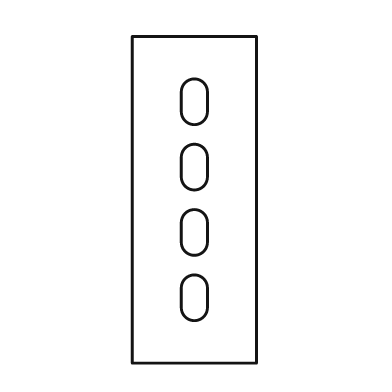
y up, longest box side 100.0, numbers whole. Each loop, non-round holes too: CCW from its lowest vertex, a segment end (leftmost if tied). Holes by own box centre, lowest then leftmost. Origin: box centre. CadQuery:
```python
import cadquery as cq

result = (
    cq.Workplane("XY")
    .moveTo(-19.0, -50.0)
    .lineTo(19.0, -50.0)
    .lineTo(19.0, 50.0)
    .lineTo(-19.0, 50.0)
    .close()
    .moveTo(-4.0, -33.0)
    .threePointArc((0.0, -37.0), (4.0, -33.0))
    .lineTo(4.0, -27.0)
    .threePointArc((0.0, -23.0), (-4.0, -27.0))
    .close()
    .moveTo(-4.0, -13.0)
    .threePointArc((0.0, -17.0), (4.0, -13.0))
    .lineTo(4.0, -7.0)
    .threePointArc((0.0, -3.0), (-4.0, -7.0))
    .close()
    .moveTo(-4.0, 7.0)
    .threePointArc((0.0, 3.0), (4.0, 7.0))
    .lineTo(4.0, 13.0)
    .threePointArc((0.0, 17.0), (-4.0, 13.0))
    .close()
    .moveTo(-4.0, 27.0)
    .threePointArc((0.0, 23.0), (4.0, 27.0))
    .lineTo(4.0, 33.0)
    .threePointArc((0.0, 37.0), (-4.0, 33.0))
    .close()
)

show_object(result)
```